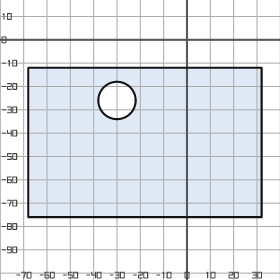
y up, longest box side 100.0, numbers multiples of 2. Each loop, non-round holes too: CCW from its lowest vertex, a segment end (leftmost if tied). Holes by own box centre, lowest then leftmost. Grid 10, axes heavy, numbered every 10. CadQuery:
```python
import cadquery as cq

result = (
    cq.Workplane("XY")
    .moveTo(-68.0, -76.0)
    .lineTo(32.0, -76.0)
    .lineTo(32.0, -12.0)
    .lineTo(-68.0, -12.0)
    .close()
    .moveTo(-30.0, -26.0)
    .circle(8.0)
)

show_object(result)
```